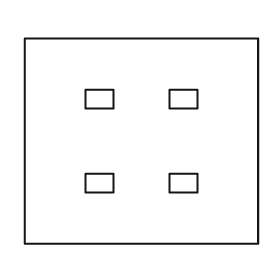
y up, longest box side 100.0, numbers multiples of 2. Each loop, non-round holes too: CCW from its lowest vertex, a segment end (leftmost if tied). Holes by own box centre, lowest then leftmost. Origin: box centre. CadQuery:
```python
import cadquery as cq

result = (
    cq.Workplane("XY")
    .moveTo(-50.0, -44.0)
    .lineTo(50.0, -44.0)
    .lineTo(50.0, 44.0)
    .lineTo(-50.0, 44.0)
    .close()
    .moveTo(-24.0, -22.0)
    .lineTo(-12.0, -22.0)
    .lineTo(-12.0, -14.0)
    .lineTo(-24.0, -14.0)
    .close()
    .moveTo(12.0, -22.0)
    .lineTo(24.0, -22.0)
    .lineTo(24.0, -14.0)
    .lineTo(12.0, -14.0)
    .close()
    .moveTo(-24.0, 14.0)
    .lineTo(-12.0, 14.0)
    .lineTo(-12.0, 22.0)
    .lineTo(-24.0, 22.0)
    .close()
    .moveTo(12.0, 14.0)
    .lineTo(24.0, 14.0)
    .lineTo(24.0, 22.0)
    .lineTo(12.0, 22.0)
    .close()
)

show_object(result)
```